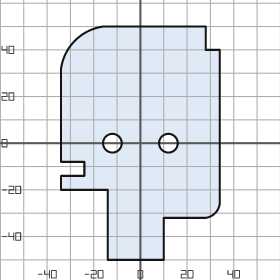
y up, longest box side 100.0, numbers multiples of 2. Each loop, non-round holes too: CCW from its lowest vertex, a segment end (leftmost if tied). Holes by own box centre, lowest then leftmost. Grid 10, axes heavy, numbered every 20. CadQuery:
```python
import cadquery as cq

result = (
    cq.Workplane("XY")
    .moveTo(-14.0, -50.0)
    .lineTo(10.0, -50.0)
    .lineTo(10.0, -32.0)
    .lineTo(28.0, -32.0)
    .threePointArc((32.0, -30.0), (34.0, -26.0))
    .lineTo(34.0, 40.0)
    .lineTo(28.0, 40.0)
    .lineTo(28.0, 50.0)
    .lineTo(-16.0, 50.0)
    .threePointArc((-28.0, 44.0), (-34.0, 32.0))
    .lineTo(-34.0, -8.0)
    .lineTo(-24.0, -8.0)
    .lineTo(-24.0, -14.0)
    .lineTo(-34.0, -14.0)
    .lineTo(-34.0, -20.0)
    .lineTo(-14.0, -20.0)
    .close()
    .moveTo(-12.0, 0.0)
    .circle(4.0)
    .moveTo(12.0, 0.0)
    .circle(4.0)
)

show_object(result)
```